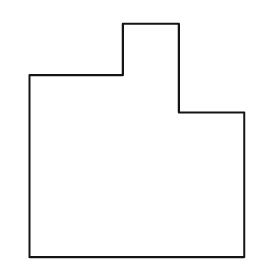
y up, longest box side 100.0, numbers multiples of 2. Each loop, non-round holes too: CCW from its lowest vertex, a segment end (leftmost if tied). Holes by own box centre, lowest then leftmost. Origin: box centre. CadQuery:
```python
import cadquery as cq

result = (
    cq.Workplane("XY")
    .moveTo(-46.0, -50.0)
    .lineTo(46.0, -50.0)
    .lineTo(46.0, 12.0)
    .lineTo(18.0, 12.0)
    .lineTo(18.0, 50.0)
    .lineTo(-6.0, 50.0)
    .lineTo(-6.0, 28.0)
    .lineTo(-46.0, 28.0)
    .close()
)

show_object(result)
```